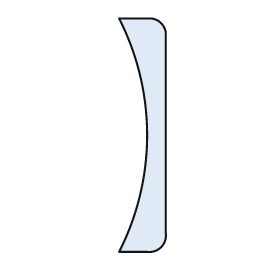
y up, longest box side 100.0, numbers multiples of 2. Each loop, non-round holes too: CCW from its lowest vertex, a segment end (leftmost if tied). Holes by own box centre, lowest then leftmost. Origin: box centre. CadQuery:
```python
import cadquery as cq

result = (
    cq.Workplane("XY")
    .moveTo(-10.0, -50.0)
    .lineTo(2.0, -50.0)
    .threePointArc((8.0, -48.0), (10.0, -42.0))
    .lineTo(10.0, 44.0)
    .threePointArc((8.0, 48.0), (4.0, 50.0))
    .lineTo(-10.0, 50.0)
    .threePointArc((2.0, 0.0), (-10.0, -50.0))
    .close()
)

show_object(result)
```